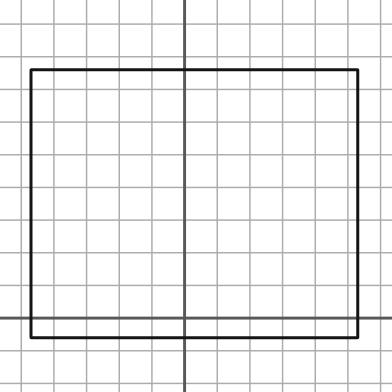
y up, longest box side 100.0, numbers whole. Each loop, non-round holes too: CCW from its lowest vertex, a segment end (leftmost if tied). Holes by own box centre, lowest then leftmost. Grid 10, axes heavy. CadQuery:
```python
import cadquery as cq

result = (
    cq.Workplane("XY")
    .moveTo(-47.0, -6.0)
    .lineTo(53.0, -6.0)
    .lineTo(53.0, 76.0)
    .lineTo(-47.0, 76.0)
    .close()
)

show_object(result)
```